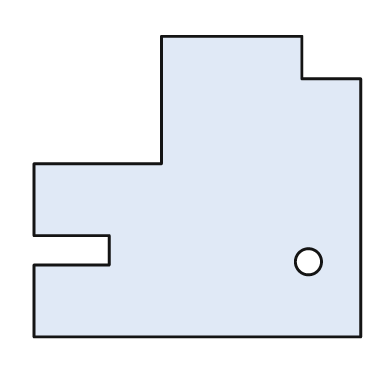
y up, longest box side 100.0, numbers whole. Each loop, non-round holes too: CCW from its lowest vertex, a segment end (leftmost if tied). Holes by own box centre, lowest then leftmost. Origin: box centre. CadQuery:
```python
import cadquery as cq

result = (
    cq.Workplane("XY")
    .moveTo(-50.0, -46.0)
    .lineTo(50.0, -46.0)
    .lineTo(50.0, 33.0)
    .lineTo(32.0, 33.0)
    .lineTo(32.0, 46.0)
    .lineTo(-11.0, 46.0)
    .lineTo(-11.0, 7.0)
    .lineTo(-50.0, 7.0)
    .lineTo(-50.0, -15.0)
    .lineTo(-27.0, -15.0)
    .lineTo(-27.0, -24.0)
    .lineTo(-50.0, -24.0)
    .close()
    .moveTo(34.0, -23.0)
    .circle(4.0)
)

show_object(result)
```